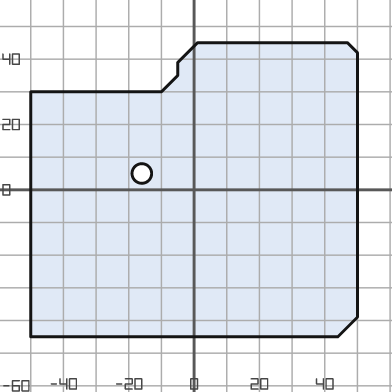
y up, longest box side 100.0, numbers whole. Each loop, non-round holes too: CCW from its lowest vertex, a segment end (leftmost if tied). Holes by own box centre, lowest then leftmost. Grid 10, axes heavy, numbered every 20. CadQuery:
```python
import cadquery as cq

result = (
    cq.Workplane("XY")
    .moveTo(-50.0, -45.0)
    .lineTo(44.0, -45.0)
    .lineTo(50.0, -39.0)
    .lineTo(50.0, 42.0)
    .lineTo(47.0, 45.0)
    .lineTo(1.0, 45.0)
    .lineTo(-5.0, 39.0)
    .lineTo(-5.0, 35.0)
    .lineTo(-10.0, 30.0)
    .lineTo(-50.0, 30.0)
    .close()
    .moveTo(-16.0, 5.0)
    .circle(3.0)
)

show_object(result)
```